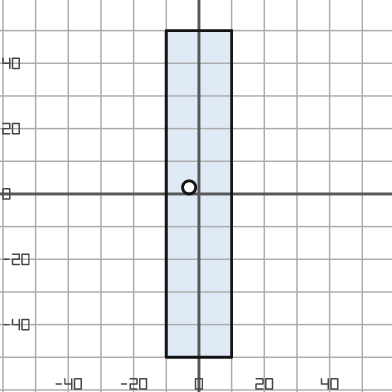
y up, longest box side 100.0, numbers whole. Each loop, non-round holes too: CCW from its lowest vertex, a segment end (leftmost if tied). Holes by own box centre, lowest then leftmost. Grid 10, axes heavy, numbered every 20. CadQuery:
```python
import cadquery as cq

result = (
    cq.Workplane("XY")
    .moveTo(-10.0, -50.0)
    .lineTo(10.0, -50.0)
    .lineTo(10.0, 50.0)
    .lineTo(-10.0, 50.0)
    .close()
    .moveTo(-3.0, 2.0)
    .circle(2.0)
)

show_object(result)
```